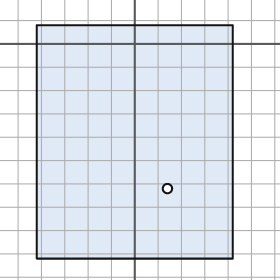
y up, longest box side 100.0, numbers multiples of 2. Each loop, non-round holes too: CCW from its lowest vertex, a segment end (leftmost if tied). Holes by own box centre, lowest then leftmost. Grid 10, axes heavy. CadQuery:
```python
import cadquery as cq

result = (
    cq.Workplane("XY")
    .moveTo(-42.0, -92.0)
    .lineTo(42.0, -92.0)
    .lineTo(42.0, 8.0)
    .lineTo(-42.0, 8.0)
    .close()
    .moveTo(14.0, -62.0)
    .circle(2.0)
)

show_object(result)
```